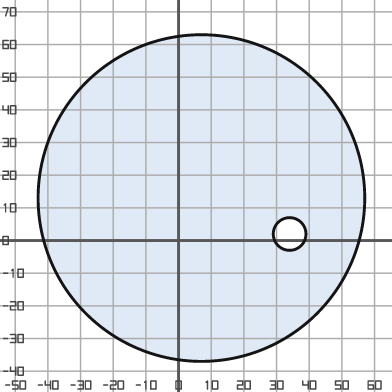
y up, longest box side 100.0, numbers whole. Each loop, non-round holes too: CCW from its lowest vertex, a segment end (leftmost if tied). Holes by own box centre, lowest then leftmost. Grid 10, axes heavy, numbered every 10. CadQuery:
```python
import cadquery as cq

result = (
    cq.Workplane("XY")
    .moveTo(7.0, 13.0)
    .circle(50.0)
    .moveTo(34.0, 2.0)
    .circle(5.0)
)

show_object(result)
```